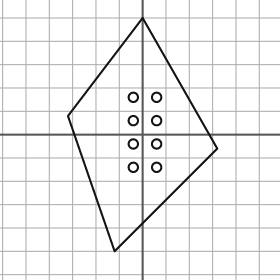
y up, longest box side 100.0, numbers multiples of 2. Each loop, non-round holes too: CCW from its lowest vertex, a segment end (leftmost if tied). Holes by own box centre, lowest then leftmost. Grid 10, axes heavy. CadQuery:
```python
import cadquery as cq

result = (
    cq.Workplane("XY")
    .moveTo(-12.0, -50.0)
    .lineTo(32.0, -6.0)
    .lineTo(0.0, 50.0)
    .lineTo(-32.0, 8.0)
    .close()
    .moveTo(-4.0, -14.0)
    .circle(2.0)
    .moveTo(6.0, -14.0)
    .circle(2.0)
    .moveTo(-4.0, -4.0)
    .circle(2.0)
    .moveTo(6.0, -4.0)
    .circle(2.0)
    .moveTo(-4.0, 6.0)
    .circle(2.0)
    .moveTo(6.0, 6.0)
    .circle(2.0)
    .moveTo(-4.0, 16.0)
    .circle(2.0)
    .moveTo(6.0, 16.0)
    .circle(2.0)
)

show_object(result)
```